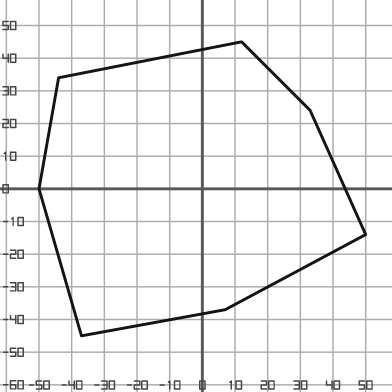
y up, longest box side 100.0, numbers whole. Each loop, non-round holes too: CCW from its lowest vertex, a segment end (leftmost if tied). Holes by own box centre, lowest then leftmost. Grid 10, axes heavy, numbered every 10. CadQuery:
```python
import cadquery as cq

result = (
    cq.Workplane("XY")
    .moveTo(-37.0, -45.0)
    .lineTo(7.0, -37.0)
    .lineTo(50.0, -14.0)
    .lineTo(33.0, 24.0)
    .lineTo(12.0, 45.0)
    .lineTo(-44.0, 34.0)
    .lineTo(-50.0, 0.0)
    .close()
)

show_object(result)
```